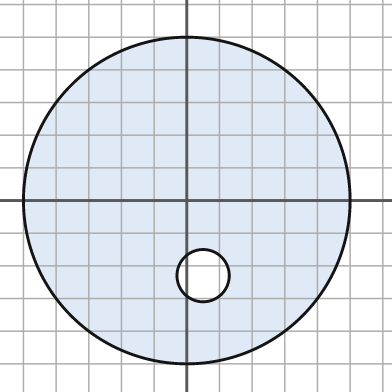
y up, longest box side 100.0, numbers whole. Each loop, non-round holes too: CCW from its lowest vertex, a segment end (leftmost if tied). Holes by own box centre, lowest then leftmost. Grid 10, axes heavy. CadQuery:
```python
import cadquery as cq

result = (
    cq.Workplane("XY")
    .moveTo(0.0, 0.0)
    .circle(50.0)
    .moveTo(5.0, -23.0)
    .circle(8.0)
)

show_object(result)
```